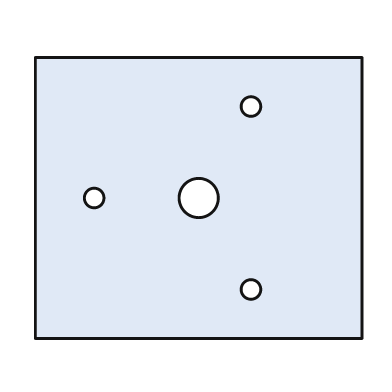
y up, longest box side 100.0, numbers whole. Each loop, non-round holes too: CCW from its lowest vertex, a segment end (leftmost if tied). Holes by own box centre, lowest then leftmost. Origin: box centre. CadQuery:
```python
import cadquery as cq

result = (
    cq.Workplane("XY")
    .moveTo(-50.0, -43.0)
    .lineTo(50.0, -43.0)
    .lineTo(50.0, 43.0)
    .lineTo(-50.0, 43.0)
    .close()
    .moveTo(16.0, -28.0)
    .circle(3.0)
    .moveTo(-32.0, 0.0)
    .circle(3.0)
    .moveTo(0.0, 0.0)
    .circle(6.0)
    .moveTo(16.0, 28.0)
    .circle(3.0)
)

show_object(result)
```